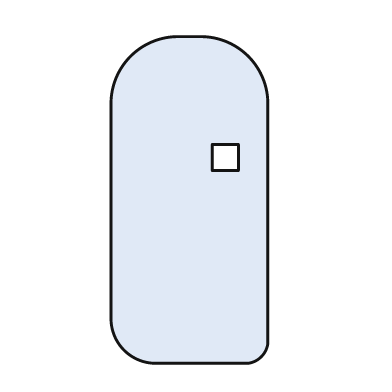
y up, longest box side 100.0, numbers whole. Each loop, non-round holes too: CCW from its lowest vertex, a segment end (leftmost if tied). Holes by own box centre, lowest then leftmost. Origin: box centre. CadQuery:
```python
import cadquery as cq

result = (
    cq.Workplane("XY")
    .moveTo(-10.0, -50.0)
    .lineTo(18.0, -50.0)
    .threePointArc((22.0, -48.0), (24.0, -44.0))
    .lineTo(24.0, 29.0)
    .threePointArc((18.0, 44.0), (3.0, 50.0))
    .lineTo(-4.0, 50.0)
    .threePointArc((-18.0, 44.0), (-24.0, 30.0))
    .lineTo(-24.0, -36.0)
    .threePointArc((-20.0, -46.0), (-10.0, -50.0))
    .close()
    .moveTo(7.0, 9.0)
    .lineTo(15.0, 9.0)
    .lineTo(15.0, 17.0)
    .lineTo(7.0, 17.0)
    .close()
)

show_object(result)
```